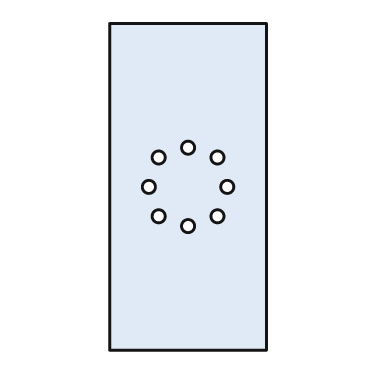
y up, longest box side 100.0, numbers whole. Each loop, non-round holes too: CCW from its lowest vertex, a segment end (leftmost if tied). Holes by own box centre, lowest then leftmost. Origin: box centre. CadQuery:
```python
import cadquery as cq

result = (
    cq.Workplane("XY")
    .moveTo(-24.0, -50.0)
    .lineTo(24.0, -50.0)
    .lineTo(24.0, 50.0)
    .lineTo(-24.0, 50.0)
    .close()
    .moveTo(0.0, -12.0)
    .circle(2.0)
    .moveTo(-9.0, -9.0)
    .circle(2.0)
    .moveTo(9.0, -9.0)
    .circle(2.0)
    .moveTo(-12.0, 0.0)
    .circle(2.0)
    .moveTo(12.0, 0.0)
    .circle(2.0)
    .moveTo(-9.0, 9.0)
    .circle(2.0)
    .moveTo(9.0, 9.0)
    .circle(2.0)
    .moveTo(0.0, 12.0)
    .circle(2.0)
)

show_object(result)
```